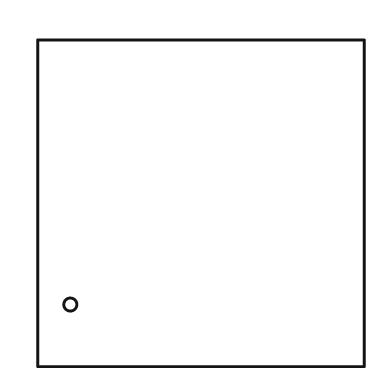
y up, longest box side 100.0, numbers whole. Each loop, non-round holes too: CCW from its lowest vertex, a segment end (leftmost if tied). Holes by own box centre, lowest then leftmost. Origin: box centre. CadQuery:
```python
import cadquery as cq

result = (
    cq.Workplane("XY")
    .moveTo(-50.0, -50.0)
    .lineTo(50.0, -50.0)
    .lineTo(50.0, 50.0)
    .lineTo(-50.0, 50.0)
    .close()
    .moveTo(-40.0, -31.0)
    .circle(2.0)
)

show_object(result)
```